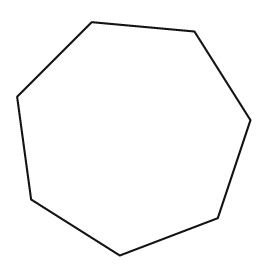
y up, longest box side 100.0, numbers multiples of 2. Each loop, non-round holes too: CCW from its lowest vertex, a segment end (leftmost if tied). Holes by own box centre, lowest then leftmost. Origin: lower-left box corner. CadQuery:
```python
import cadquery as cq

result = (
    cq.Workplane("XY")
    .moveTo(44.0, 0.0)
    .lineTo(86.0, 16.0)
    .lineTo(100.0, 58.0)
    .lineTo(76.0, 96.0)
    .lineTo(32.0, 100.0)
    .lineTo(0.0, 68.0)
    .lineTo(6.0, 24.0)
    .close()
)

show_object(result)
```